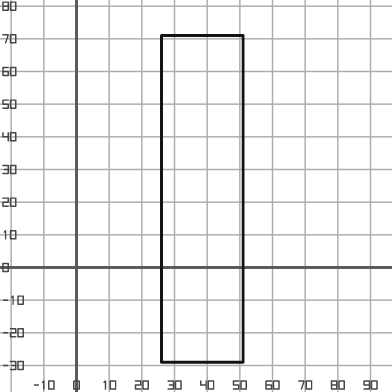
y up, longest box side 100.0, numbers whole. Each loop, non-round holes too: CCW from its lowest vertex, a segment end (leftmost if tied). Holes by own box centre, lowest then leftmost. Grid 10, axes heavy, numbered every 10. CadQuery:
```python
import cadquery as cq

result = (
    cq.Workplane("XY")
    .moveTo(26.0, -29.0)
    .lineTo(51.0, -29.0)
    .lineTo(51.0, 71.0)
    .lineTo(26.0, 71.0)
    .close()
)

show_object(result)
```